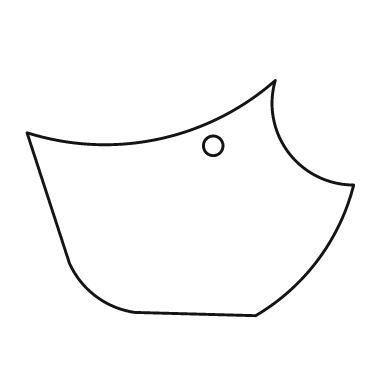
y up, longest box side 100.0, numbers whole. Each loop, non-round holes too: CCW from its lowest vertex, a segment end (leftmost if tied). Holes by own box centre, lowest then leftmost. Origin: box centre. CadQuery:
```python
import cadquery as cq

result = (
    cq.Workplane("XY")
    .moveTo(20.0, -36.0)
    .threePointArc((39.0, -19.0), (50.0, 4.0))
    .threePointArc((30.0, 14.0), (26.0, 36.0))
    .threePointArc((-10.0, 18.0), (-50.0, 20.0))
    .lineTo(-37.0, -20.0)
    .threePointArc((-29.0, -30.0), (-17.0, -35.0))
    .close()
    .moveTo(7.0, 16.0)
    .circle(3.0)
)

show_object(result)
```